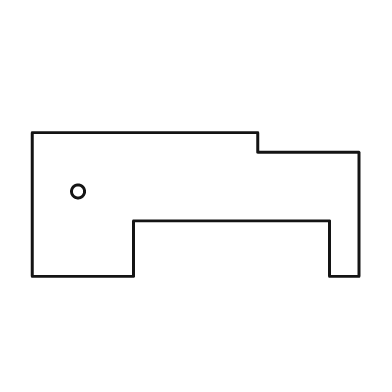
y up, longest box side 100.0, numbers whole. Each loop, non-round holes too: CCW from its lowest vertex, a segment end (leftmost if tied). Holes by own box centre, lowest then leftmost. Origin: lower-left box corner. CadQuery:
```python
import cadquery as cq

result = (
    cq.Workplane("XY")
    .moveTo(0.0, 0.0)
    .lineTo(31.0, 0.0)
    .lineTo(31.0, 17.0)
    .lineTo(91.0, 17.0)
    .lineTo(91.0, 0.0)
    .lineTo(100.0, 0.0)
    .lineTo(100.0, 38.0)
    .lineTo(69.0, 38.0)
    .lineTo(69.0, 44.0)
    .lineTo(0.0, 44.0)
    .close()
    .moveTo(14.0, 26.0)
    .circle(2.0)
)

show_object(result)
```